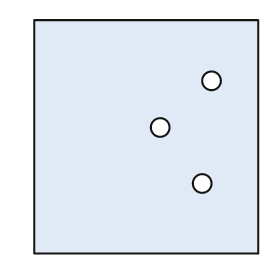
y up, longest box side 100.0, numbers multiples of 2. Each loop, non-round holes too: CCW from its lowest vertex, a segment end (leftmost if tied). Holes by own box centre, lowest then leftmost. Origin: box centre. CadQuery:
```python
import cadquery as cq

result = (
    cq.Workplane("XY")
    .moveTo(-48.0, -50.0)
    .lineTo(48.0, -50.0)
    .lineTo(48.0, 50.0)
    .lineTo(-48.0, 50.0)
    .close()
    .moveTo(24.0, -20.0)
    .circle(4.0)
    .moveTo(6.0, 4.0)
    .circle(4.0)
    .moveTo(28.0, 24.0)
    .circle(4.0)
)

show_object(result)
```